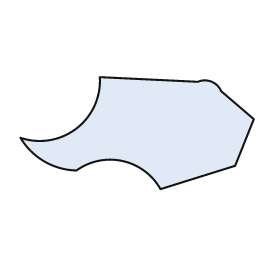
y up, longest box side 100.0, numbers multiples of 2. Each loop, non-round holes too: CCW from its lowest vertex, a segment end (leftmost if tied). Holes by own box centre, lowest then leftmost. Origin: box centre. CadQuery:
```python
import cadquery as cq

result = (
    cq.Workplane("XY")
    .moveTo(10.0, -24.0)
    .lineTo(42.0, -14.0)
    .lineTo(50.0, 6.0)
    .lineTo(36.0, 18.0)
    .threePointArc((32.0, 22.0), (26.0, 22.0))
    .lineTo(-16.0, 24.0)
    .threePointArc((-26.0, 2.0), (-50.0, -2.0))
    .threePointArc((-40.0, -12.0), (-26.0, -16.0))
    .threePointArc((-6.0, -12.0), (10.0, -24.0))
    .close()
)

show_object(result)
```